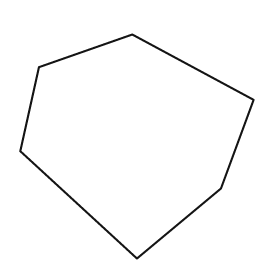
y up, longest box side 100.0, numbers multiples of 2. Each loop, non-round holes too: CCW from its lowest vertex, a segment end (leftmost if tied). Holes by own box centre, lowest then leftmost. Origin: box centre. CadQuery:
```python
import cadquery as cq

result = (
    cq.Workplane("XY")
    .moveTo(0.0, -48.0)
    .lineTo(36.0, -18.0)
    .lineTo(50.0, 20.0)
    .lineTo(-2.0, 48.0)
    .lineTo(-42.0, 34.0)
    .lineTo(-50.0, -2.0)
    .close()
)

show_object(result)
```